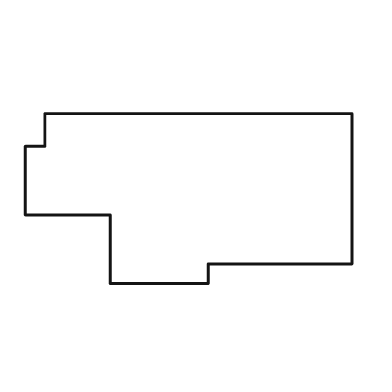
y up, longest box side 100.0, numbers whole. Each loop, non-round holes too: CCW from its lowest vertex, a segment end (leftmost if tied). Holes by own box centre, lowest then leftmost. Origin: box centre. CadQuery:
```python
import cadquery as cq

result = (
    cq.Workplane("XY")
    .moveTo(-24.0, -26.0)
    .lineTo(6.0, -26.0)
    .lineTo(6.0, -20.0)
    .lineTo(50.0, -20.0)
    .lineTo(50.0, 26.0)
    .lineTo(-44.0, 26.0)
    .lineTo(-44.0, 16.0)
    .lineTo(-50.0, 16.0)
    .lineTo(-50.0, -5.0)
    .lineTo(-24.0, -5.0)
    .close()
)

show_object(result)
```